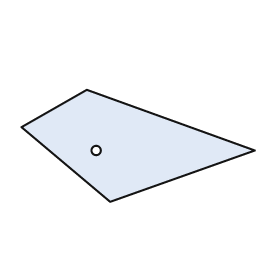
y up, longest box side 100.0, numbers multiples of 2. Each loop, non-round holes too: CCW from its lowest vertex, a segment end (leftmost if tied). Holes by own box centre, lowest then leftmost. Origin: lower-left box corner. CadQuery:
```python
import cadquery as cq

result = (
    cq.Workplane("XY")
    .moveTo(38.0, 0.0)
    .lineTo(100.0, 22.0)
    .lineTo(28.0, 48.0)
    .lineTo(0.0, 32.0)
    .close()
    .moveTo(32.0, 22.0)
    .circle(2.0)
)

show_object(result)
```